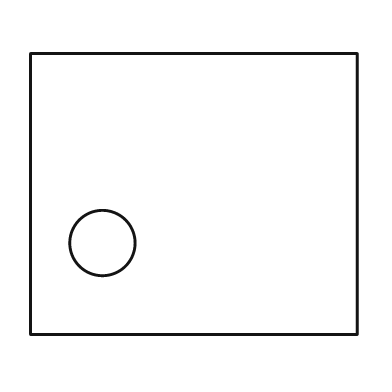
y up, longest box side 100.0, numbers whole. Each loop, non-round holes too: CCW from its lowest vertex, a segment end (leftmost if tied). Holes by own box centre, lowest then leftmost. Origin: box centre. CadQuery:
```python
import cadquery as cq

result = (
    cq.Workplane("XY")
    .moveTo(-50.0, -43.0)
    .lineTo(50.0, -43.0)
    .lineTo(50.0, 43.0)
    .lineTo(-50.0, 43.0)
    .close()
    .moveTo(-28.0, -15.0)
    .circle(10.0)
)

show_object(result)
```